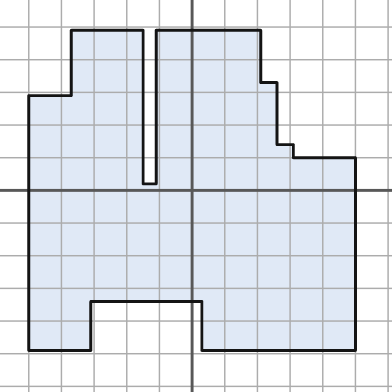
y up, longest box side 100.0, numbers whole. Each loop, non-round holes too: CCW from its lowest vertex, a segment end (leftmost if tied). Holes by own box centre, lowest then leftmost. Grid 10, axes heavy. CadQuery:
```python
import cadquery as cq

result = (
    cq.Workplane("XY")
    .moveTo(-50.0, -49.0)
    .lineTo(-31.0, -49.0)
    .lineTo(-31.0, -34.0)
    .lineTo(3.0, -34.0)
    .lineTo(3.0, -49.0)
    .lineTo(50.0, -49.0)
    .lineTo(50.0, 10.0)
    .lineTo(31.0, 10.0)
    .lineTo(31.0, 14.0)
    .lineTo(26.0, 14.0)
    .lineTo(26.0, 33.0)
    .lineTo(21.0, 33.0)
    .lineTo(21.0, 49.0)
    .lineTo(-11.0, 49.0)
    .lineTo(-11.0, 2.0)
    .lineTo(-15.0, 2.0)
    .lineTo(-15.0, 49.0)
    .lineTo(-37.0, 49.0)
    .lineTo(-37.0, 29.0)
    .lineTo(-50.0, 29.0)
    .close()
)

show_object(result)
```